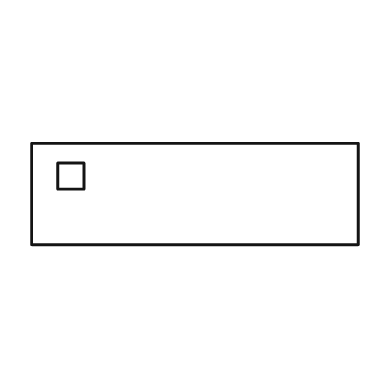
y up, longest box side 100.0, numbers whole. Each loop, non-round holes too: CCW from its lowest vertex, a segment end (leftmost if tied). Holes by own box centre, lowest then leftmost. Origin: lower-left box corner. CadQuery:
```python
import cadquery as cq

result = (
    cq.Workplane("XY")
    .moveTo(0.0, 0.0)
    .lineTo(100.0, 0.0)
    .lineTo(100.0, 31.0)
    .lineTo(0.0, 31.0)
    .close()
    .moveTo(8.0, 17.0)
    .lineTo(16.0, 17.0)
    .lineTo(16.0, 25.0)
    .lineTo(8.0, 25.0)
    .close()
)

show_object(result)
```